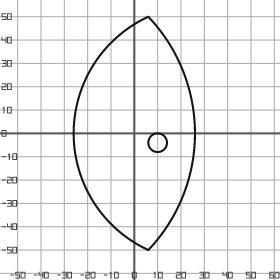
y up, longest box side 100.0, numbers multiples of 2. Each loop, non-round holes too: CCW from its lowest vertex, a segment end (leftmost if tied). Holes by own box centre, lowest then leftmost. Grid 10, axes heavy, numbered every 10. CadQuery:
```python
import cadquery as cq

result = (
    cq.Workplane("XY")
    .moveTo(6.0, -50.0)
    .threePointArc((26.0, 0.0), (6.0, 50.0))
    .threePointArc((-26.0, 0.0), (6.0, -50.0))
    .close()
    .moveTo(10.0, -4.0)
    .circle(4.0)
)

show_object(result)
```